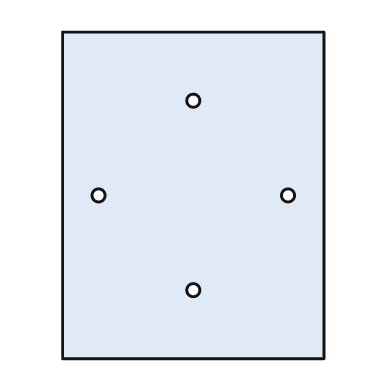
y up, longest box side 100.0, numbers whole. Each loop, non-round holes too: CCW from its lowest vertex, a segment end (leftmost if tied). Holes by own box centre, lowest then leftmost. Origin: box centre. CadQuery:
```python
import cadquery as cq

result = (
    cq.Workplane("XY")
    .moveTo(-40.0, -50.0)
    .lineTo(40.0, -50.0)
    .lineTo(40.0, 50.0)
    .lineTo(-40.0, 50.0)
    .close()
    .moveTo(0.0, -29.0)
    .circle(2.0)
    .moveTo(-29.0, 0.0)
    .circle(2.0)
    .moveTo(29.0, 0.0)
    .circle(2.0)
    .moveTo(0.0, 29.0)
    .circle(2.0)
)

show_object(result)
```